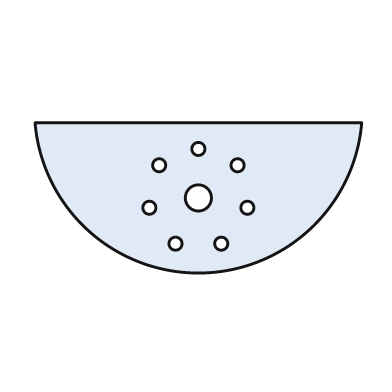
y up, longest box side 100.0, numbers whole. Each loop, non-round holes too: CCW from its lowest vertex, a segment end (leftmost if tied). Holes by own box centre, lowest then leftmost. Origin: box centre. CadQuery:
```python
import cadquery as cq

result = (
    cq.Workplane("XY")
    .moveTo(-50.0, 23.0)
    .threePointArc((0.0, -23.0), (50.0, 23.0))
    .close()
    .moveTo(-7.0, -14.0)
    .circle(2.0)
    .moveTo(7.0, -14.0)
    .circle(2.0)
    .moveTo(-15.0, -3.0)
    .circle(2.0)
    .moveTo(15.0, -3.0)
    .circle(2.0)
    .moveTo(0.0, 0.0)
    .circle(4.0)
    .moveTo(-12.0, 10.0)
    .circle(2.0)
    .moveTo(12.0, 10.0)
    .circle(2.0)
    .moveTo(0.0, 15.0)
    .circle(2.0)
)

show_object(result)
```